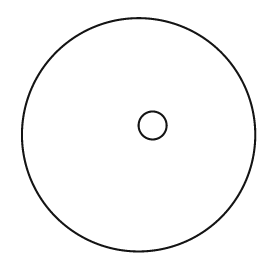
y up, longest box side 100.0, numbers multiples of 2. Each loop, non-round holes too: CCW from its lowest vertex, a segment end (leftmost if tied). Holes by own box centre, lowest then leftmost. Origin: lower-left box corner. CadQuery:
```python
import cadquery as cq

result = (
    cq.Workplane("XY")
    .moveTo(50.0, 50.0)
    .circle(50.0)
    .moveTo(56.0, 54.0)
    .circle(6.0)
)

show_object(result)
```